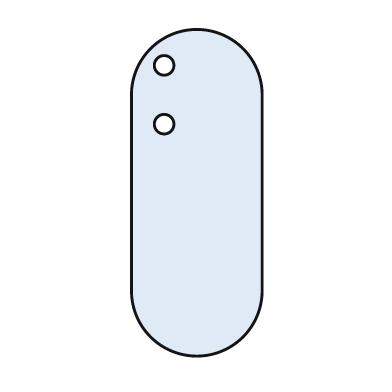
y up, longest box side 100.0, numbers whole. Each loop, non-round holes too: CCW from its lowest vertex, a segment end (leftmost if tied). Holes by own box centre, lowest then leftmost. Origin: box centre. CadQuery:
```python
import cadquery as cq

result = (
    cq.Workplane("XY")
    .moveTo(-20.0, -30.0)
    .threePointArc((0.0, -50.0), (20.0, -30.0))
    .lineTo(20.0, 30.0)
    .threePointArc((0.0, 50.0), (-20.0, 30.0))
    .close()
    .moveTo(-10.0, 21.0)
    .circle(3.0)
    .moveTo(-10.0, 39.0)
    .circle(3.0)
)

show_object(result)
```